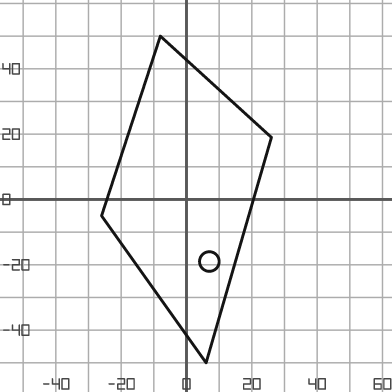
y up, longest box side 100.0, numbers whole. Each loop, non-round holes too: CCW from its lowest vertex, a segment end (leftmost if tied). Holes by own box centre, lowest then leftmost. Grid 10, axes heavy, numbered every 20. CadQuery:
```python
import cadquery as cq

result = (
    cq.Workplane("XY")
    .moveTo(6.0, -50.0)
    .lineTo(26.0, 19.0)
    .lineTo(-8.0, 50.0)
    .lineTo(-26.0, -5.0)
    .close()
    .moveTo(7.0, -19.0)
    .circle(3.0)
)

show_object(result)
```